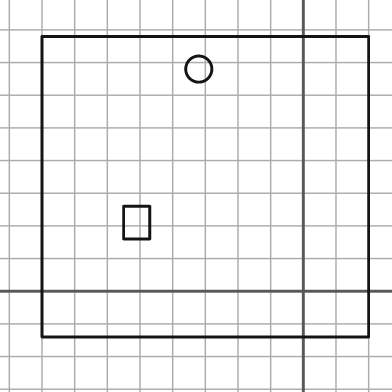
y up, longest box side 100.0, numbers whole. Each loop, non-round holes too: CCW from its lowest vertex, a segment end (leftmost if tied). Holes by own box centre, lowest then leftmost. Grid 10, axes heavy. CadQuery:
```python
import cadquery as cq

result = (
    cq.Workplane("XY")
    .moveTo(-80.0, -14.0)
    .lineTo(20.0, -14.0)
    .lineTo(20.0, 78.0)
    .lineTo(-80.0, 78.0)
    .close()
    .moveTo(-55.0, 16.0)
    .lineTo(-47.0, 16.0)
    .lineTo(-47.0, 26.0)
    .lineTo(-55.0, 26.0)
    .close()
    .moveTo(-32.0, 68.0)
    .circle(4.0)
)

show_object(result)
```